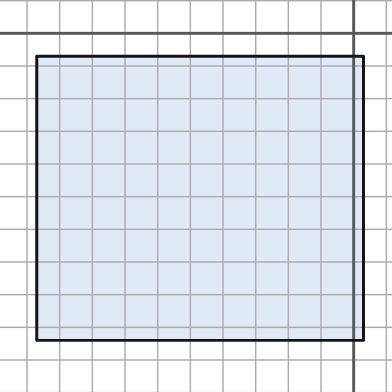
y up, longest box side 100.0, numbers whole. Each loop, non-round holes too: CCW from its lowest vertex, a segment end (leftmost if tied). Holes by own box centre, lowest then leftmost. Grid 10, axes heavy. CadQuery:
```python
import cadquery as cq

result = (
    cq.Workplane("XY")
    .moveTo(-97.0, -94.0)
    .lineTo(3.0, -94.0)
    .lineTo(3.0, -7.0)
    .lineTo(-97.0, -7.0)
    .close()
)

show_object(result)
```